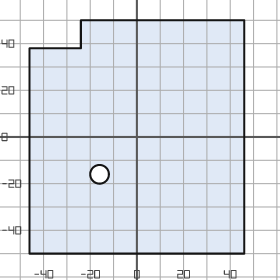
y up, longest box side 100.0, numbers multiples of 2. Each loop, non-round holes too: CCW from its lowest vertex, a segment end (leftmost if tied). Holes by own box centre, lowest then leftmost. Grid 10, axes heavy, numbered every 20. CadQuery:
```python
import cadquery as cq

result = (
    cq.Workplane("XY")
    .moveTo(-46.0, -50.0)
    .lineTo(46.0, -50.0)
    .lineTo(46.0, 50.0)
    .lineTo(-24.0, 50.0)
    .lineTo(-24.0, 38.0)
    .lineTo(-46.0, 38.0)
    .close()
    .moveTo(-16.0, -16.0)
    .circle(4.0)
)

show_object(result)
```